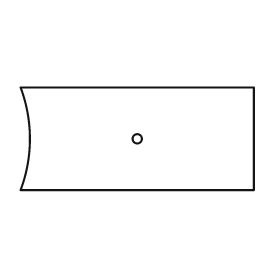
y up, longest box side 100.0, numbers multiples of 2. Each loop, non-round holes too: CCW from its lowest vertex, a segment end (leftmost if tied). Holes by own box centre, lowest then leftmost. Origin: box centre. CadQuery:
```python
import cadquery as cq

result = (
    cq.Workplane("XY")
    .moveTo(-50.0, -22.0)
    .lineTo(50.0, -22.0)
    .lineTo(50.0, 22.0)
    .lineTo(-50.0, 22.0)
    .threePointArc((-46.0, 0.0), (-50.0, -22.0))
    .close()
    .moveTo(0.0, 0.0)
    .circle(2.0)
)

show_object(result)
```